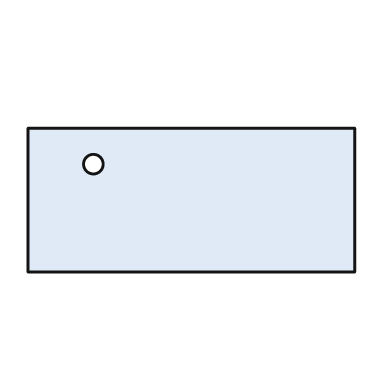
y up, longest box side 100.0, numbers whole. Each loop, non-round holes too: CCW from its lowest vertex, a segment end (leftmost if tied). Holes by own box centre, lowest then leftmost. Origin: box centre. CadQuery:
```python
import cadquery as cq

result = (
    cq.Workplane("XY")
    .moveTo(-50.0, -22.0)
    .lineTo(50.0, -22.0)
    .lineTo(50.0, 22.0)
    .lineTo(-50.0, 22.0)
    .close()
    .moveTo(-30.0, 11.0)
    .circle(3.0)
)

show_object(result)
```